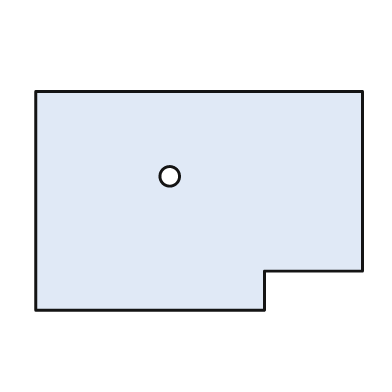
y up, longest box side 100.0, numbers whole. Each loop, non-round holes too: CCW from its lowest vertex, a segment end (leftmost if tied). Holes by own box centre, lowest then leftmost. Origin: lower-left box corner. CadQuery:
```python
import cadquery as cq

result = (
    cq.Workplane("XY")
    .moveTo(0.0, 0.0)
    .lineTo(70.0, 0.0)
    .lineTo(70.0, 12.0)
    .lineTo(100.0, 12.0)
    .lineTo(100.0, 67.0)
    .lineTo(0.0, 67.0)
    .close()
    .moveTo(41.0, 41.0)
    .circle(3.0)
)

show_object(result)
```